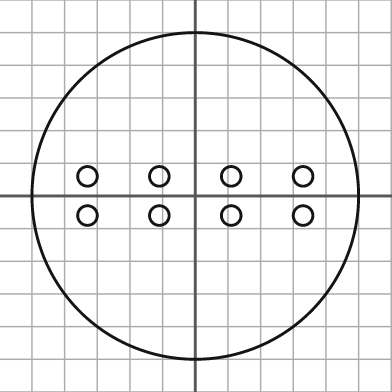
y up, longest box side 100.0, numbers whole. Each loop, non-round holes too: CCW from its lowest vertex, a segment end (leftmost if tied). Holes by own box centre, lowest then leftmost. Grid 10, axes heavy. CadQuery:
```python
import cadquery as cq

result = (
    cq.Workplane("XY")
    .moveTo(0.0, 0.0)
    .circle(50.0)
    .moveTo(-33.0, -6.0)
    .circle(3.0)
    .moveTo(-11.0, -6.0)
    .circle(3.0)
    .moveTo(11.0, -6.0)
    .circle(3.0)
    .moveTo(33.0, -6.0)
    .circle(3.0)
    .moveTo(-33.0, 6.0)
    .circle(3.0)
    .moveTo(-11.0, 6.0)
    .circle(3.0)
    .moveTo(11.0, 6.0)
    .circle(3.0)
    .moveTo(33.0, 6.0)
    .circle(3.0)
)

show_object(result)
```